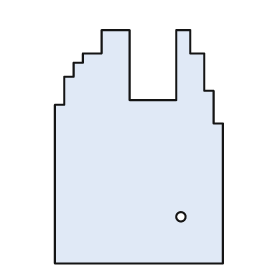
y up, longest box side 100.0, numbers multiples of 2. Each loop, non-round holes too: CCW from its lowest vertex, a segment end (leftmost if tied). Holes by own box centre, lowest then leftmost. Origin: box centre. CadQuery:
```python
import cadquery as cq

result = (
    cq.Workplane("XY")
    .moveTo(-36.0, -50.0)
    .lineTo(36.0, -50.0)
    .lineTo(36.0, 10.0)
    .lineTo(32.0, 10.0)
    .lineTo(32.0, 24.0)
    .lineTo(28.0, 24.0)
    .lineTo(28.0, 40.0)
    .lineTo(22.0, 40.0)
    .lineTo(22.0, 50.0)
    .lineTo(16.0, 50.0)
    .lineTo(16.0, 20.0)
    .lineTo(-4.0, 20.0)
    .lineTo(-4.0, 50.0)
    .lineTo(-16.0, 50.0)
    .lineTo(-16.0, 40.0)
    .lineTo(-24.0, 40.0)
    .lineTo(-24.0, 36.0)
    .lineTo(-28.0, 36.0)
    .lineTo(-28.0, 30.0)
    .lineTo(-32.0, 30.0)
    .lineTo(-32.0, 18.0)
    .lineTo(-36.0, 18.0)
    .close()
    .moveTo(18.0, -30.0)
    .circle(2.0)
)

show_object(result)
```